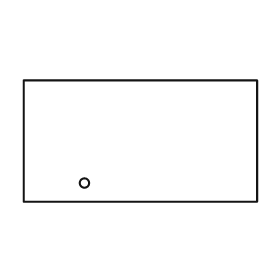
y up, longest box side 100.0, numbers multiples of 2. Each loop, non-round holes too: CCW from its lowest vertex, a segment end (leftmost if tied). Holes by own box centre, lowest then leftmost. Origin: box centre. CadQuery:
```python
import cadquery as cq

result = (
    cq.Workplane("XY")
    .moveTo(-50.0, -26.0)
    .lineTo(50.0, -26.0)
    .lineTo(50.0, 26.0)
    .lineTo(-50.0, 26.0)
    .close()
    .moveTo(-24.0, -18.0)
    .circle(2.0)
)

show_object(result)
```